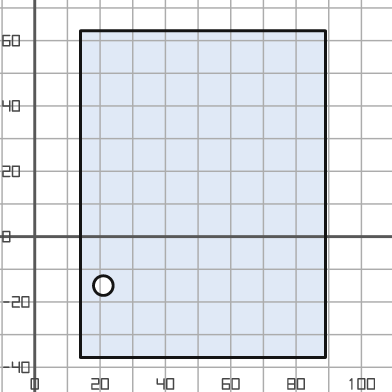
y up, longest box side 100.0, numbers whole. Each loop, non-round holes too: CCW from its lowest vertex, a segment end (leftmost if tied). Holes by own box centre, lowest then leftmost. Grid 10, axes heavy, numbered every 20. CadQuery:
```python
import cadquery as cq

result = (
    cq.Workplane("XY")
    .moveTo(14.0, -37.0)
    .lineTo(89.0, -37.0)
    .lineTo(89.0, 63.0)
    .lineTo(14.0, 63.0)
    .close()
    .moveTo(21.0, -15.0)
    .circle(3.0)
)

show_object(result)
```